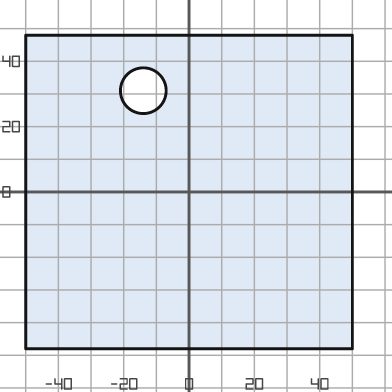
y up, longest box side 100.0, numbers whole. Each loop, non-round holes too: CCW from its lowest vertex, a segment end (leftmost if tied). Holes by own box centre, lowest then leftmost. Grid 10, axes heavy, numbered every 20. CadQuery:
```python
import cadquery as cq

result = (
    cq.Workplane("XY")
    .moveTo(-50.0, -48.0)
    .lineTo(50.0, -48.0)
    .lineTo(50.0, 48.0)
    .lineTo(-50.0, 48.0)
    .close()
    .moveTo(-14.0, 31.0)
    .circle(7.0)
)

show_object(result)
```